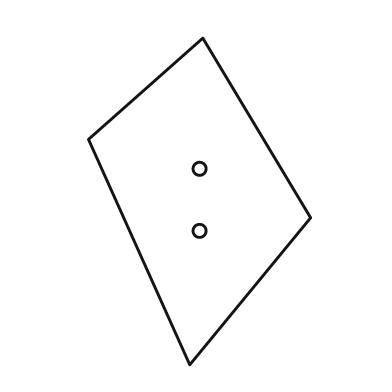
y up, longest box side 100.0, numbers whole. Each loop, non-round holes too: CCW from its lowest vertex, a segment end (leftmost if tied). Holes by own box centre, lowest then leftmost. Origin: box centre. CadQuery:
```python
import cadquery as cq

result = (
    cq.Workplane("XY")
    .moveTo(-3.0, -50.0)
    .lineTo(34.0, -5.0)
    .lineTo(1.0, 50.0)
    .lineTo(-34.0, 19.0)
    .close()
    .moveTo(0.0, -9.0)
    .circle(2.0)
    .moveTo(0.0, 10.0)
    .circle(2.0)
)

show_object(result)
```